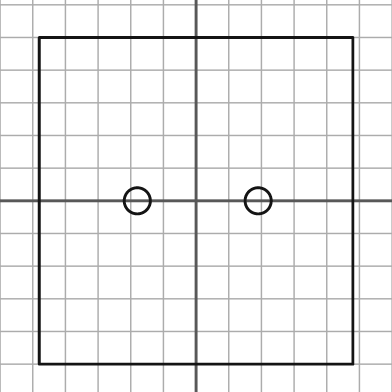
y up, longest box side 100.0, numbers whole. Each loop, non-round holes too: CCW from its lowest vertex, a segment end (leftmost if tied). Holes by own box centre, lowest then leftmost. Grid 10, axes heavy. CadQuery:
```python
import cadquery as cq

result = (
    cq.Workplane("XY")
    .moveTo(-48.0, -50.0)
    .lineTo(48.0, -50.0)
    .lineTo(48.0, 50.0)
    .lineTo(-48.0, 50.0)
    .close()
    .moveTo(-18.0, 0.0)
    .circle(4.0)
    .moveTo(19.0, 0.0)
    .circle(4.0)
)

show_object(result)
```